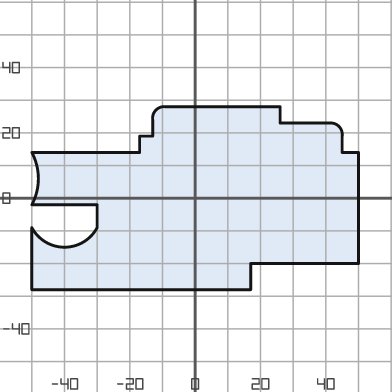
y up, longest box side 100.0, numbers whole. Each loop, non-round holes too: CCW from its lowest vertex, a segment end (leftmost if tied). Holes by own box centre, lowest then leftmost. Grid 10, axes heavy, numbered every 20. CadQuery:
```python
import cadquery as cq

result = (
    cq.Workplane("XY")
    .moveTo(-50.0, -28.0)
    .lineTo(17.0, -28.0)
    .lineTo(17.0, -20.0)
    .lineTo(50.0, -20.0)
    .lineTo(50.0, 14.0)
    .lineTo(45.0, 14.0)
    .lineTo(45.0, 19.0)
    .threePointArc((44.0, 22.0), (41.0, 23.0))
    .lineTo(26.0, 23.0)
    .lineTo(26.0, 28.0)
    .lineTo(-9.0, 28.0)
    .threePointArc((-12.0, 27.0), (-13.0, 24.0))
    .lineTo(-13.0, 19.0)
    .lineTo(-17.0, 19.0)
    .lineTo(-17.0, 14.0)
    .lineTo(-50.0, 14.0)
    .threePointArc((-48.0, 6.0), (-50.0, -2.0))
    .lineTo(-30.0, -2.0)
    .lineTo(-30.0, -9.0)
    .threePointArc((-40.0, -15.0), (-50.0, -9.0))
    .close()
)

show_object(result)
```